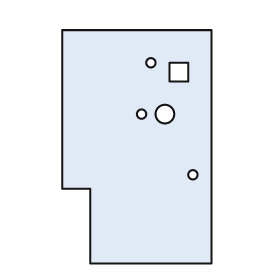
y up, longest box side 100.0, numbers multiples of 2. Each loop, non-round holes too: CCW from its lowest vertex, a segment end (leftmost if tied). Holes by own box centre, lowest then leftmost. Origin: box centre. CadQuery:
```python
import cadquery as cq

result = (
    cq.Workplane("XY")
    .moveTo(-20.0, -50.0)
    .lineTo(32.0, -50.0)
    .lineTo(32.0, 50.0)
    .lineTo(-32.0, 50.0)
    .lineTo(-32.0, -18.0)
    .lineTo(-20.0, -18.0)
    .close()
    .moveTo(24.0, -12.0)
    .circle(2.0)
    .moveTo(2.0, 14.0)
    .circle(2.0)
    .moveTo(12.0, 14.0)
    .circle(4.0)
    .moveTo(14.0, 28.0)
    .lineTo(22.0, 28.0)
    .lineTo(22.0, 36.0)
    .lineTo(14.0, 36.0)
    .close()
    .moveTo(6.0, 36.0)
    .circle(2.0)
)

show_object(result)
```